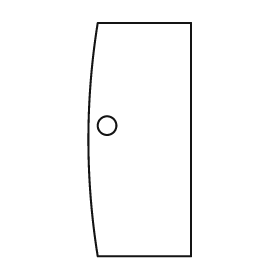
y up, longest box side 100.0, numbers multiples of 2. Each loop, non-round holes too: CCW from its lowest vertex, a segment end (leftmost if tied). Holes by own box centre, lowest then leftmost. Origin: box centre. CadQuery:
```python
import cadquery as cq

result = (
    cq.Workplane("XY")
    .moveTo(-18.0, -50.0)
    .lineTo(22.0, -50.0)
    .lineTo(22.0, 50.0)
    .lineTo(-18.0, 50.0)
    .threePointArc((-22.0, 0.0), (-18.0, -50.0))
    .close()
    .moveTo(-14.0, 6.0)
    .circle(4.0)
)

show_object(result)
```